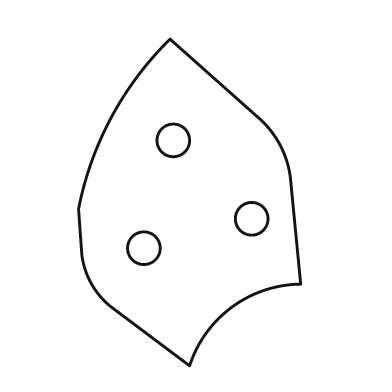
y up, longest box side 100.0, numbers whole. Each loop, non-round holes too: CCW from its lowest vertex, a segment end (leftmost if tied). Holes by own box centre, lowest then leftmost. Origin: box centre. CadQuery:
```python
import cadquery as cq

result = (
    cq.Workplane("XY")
    .moveTo(0.0, -50.0)
    .threePointArc((13.0, -32.0), (34.0, -25.0))
    .lineTo(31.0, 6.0)
    .threePointArc((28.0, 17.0), (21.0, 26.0))
    .lineTo(-6.0, 50.0)
    .threePointArc((-24.0, 26.0), (-34.0, -2.0))
    .lineTo(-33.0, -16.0)
    .threePointArc((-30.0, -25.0), (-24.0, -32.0))
    .close()
    .moveTo(-14.0, -14.0)
    .circle(5.0)
    .moveTo(19.0, -5.0)
    .circle(5.0)
    .moveTo(-5.0, 19.0)
    .circle(5.0)
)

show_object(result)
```